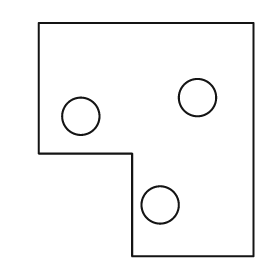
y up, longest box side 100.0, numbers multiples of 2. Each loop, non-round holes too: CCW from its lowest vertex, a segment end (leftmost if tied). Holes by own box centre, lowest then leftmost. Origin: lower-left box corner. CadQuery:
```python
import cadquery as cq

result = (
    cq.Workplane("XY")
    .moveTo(40.0, 0.0)
    .lineTo(92.0, 0.0)
    .lineTo(92.0, 100.0)
    .lineTo(0.0, 100.0)
    .lineTo(0.0, 44.0)
    .lineTo(40.0, 44.0)
    .close()
    .moveTo(52.0, 22.0)
    .circle(8.0)
    .moveTo(18.0, 60.0)
    .circle(8.0)
    .moveTo(68.0, 68.0)
    .circle(8.0)
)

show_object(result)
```